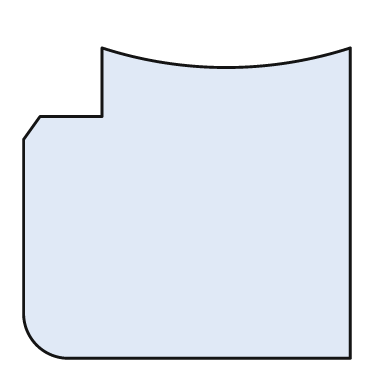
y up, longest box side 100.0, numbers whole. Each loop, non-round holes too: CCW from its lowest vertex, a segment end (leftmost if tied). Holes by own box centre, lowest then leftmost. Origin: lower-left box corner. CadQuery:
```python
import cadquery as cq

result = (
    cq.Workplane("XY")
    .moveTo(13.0, 0.0)
    .lineTo(100.0, 0.0)
    .lineTo(100.0, 95.0)
    .threePointArc((62.0, 89.0), (24.0, 95.0))
    .lineTo(24.0, 74.0)
    .lineTo(5.0, 74.0)
    .lineTo(0.0, 67.0)
    .lineTo(0.0, 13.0)
    .threePointArc((4.0, 4.0), (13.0, 0.0))
    .close()
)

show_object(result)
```